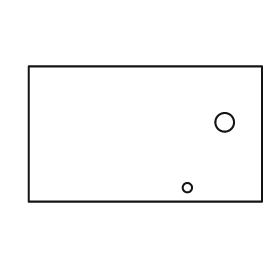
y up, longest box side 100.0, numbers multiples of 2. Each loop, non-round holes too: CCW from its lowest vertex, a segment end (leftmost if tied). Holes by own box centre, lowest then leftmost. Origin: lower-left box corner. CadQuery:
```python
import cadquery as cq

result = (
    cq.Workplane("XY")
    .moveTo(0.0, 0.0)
    .lineTo(100.0, 0.0)
    .lineTo(100.0, 58.0)
    .lineTo(0.0, 58.0)
    .close()
    .moveTo(68.0, 6.0)
    .circle(2.0)
    .moveTo(84.0, 34.0)
    .circle(4.0)
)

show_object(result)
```